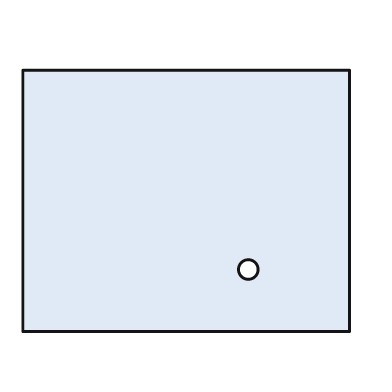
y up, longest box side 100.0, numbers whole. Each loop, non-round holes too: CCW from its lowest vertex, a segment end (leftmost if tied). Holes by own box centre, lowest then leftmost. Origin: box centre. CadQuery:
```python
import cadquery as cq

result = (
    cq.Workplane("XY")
    .moveTo(-50.0, -40.0)
    .lineTo(50.0, -40.0)
    .lineTo(50.0, 40.0)
    .lineTo(-50.0, 40.0)
    .close()
    .moveTo(19.0, -21.0)
    .circle(3.0)
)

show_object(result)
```